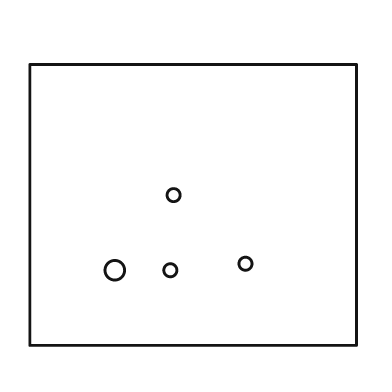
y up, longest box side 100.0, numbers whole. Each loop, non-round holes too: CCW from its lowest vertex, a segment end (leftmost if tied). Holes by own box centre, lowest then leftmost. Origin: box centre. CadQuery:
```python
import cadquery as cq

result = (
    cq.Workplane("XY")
    .moveTo(-50.0, -43.0)
    .lineTo(50.0, -43.0)
    .lineTo(50.0, 43.0)
    .lineTo(-50.0, 43.0)
    .close()
    .moveTo(-24.0, -20.0)
    .circle(3.0)
    .moveTo(-7.0, -20.0)
    .circle(2.0)
    .moveTo(16.0, -18.0)
    .circle(2.0)
    .moveTo(-6.0, 3.0)
    .circle(2.0)
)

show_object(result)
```